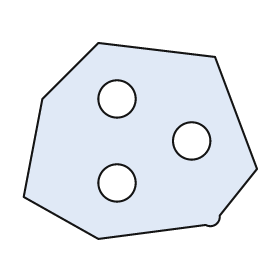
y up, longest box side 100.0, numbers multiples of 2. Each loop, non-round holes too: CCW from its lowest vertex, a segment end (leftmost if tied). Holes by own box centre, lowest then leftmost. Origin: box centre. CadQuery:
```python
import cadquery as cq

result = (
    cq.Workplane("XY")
    .moveTo(-18.0, -42.0)
    .lineTo(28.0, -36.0)
    .threePointArc((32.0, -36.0), (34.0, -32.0))
    .lineTo(50.0, -12.0)
    .lineTo(32.0, 36.0)
    .lineTo(-18.0, 42.0)
    .lineTo(-42.0, 18.0)
    .lineTo(-50.0, -24.0)
    .close()
    .moveTo(-10.0, -18.0)
    .circle(8.0)
    .moveTo(22.0, 0.0)
    .circle(8.0)
    .moveTo(-10.0, 18.0)
    .circle(8.0)
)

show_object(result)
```